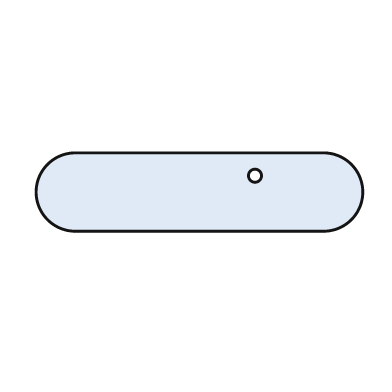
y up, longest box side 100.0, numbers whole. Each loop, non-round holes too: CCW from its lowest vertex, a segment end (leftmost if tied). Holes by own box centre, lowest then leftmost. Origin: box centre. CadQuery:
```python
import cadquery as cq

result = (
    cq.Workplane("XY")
    .moveTo(-38.0, -12.0)
    .lineTo(38.0, -12.0)
    .threePointArc((50.0, 0.0), (38.0, 12.0))
    .lineTo(-38.0, 12.0)
    .threePointArc((-50.0, 0.0), (-38.0, -12.0))
    .close()
    .moveTo(17.0, 5.0)
    .circle(2.0)
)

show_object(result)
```